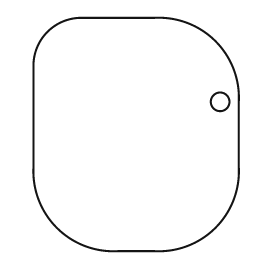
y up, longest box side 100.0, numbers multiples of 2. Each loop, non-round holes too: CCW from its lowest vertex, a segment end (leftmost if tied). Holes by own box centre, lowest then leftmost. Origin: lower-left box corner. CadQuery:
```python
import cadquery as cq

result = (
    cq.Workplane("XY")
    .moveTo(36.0, 0.0)
    .lineTo(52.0, 0.0)
    .threePointArc((78.0, 10.0), (88.0, 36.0))
    .lineTo(88.0, 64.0)
    .threePointArc((78.0, 90.0), (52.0, 100.0))
    .lineTo(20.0, 100.0)
    .threePointArc((6.0, 94.0), (0.0, 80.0))
    .lineTo(0.0, 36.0)
    .threePointArc((10.0, 10.0), (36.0, 0.0))
    .close()
    .moveTo(80.0, 64.0)
    .circle(4.0)
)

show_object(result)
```